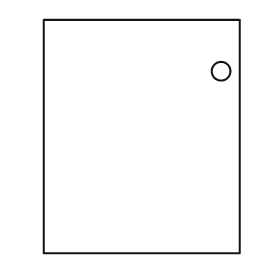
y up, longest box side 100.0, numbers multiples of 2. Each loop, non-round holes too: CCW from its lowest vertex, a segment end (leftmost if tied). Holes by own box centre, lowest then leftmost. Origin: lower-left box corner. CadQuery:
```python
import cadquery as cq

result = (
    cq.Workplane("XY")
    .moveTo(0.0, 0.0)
    .lineTo(84.0, 0.0)
    .lineTo(84.0, 100.0)
    .lineTo(0.0, 100.0)
    .close()
    .moveTo(76.0, 78.0)
    .circle(4.0)
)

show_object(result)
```